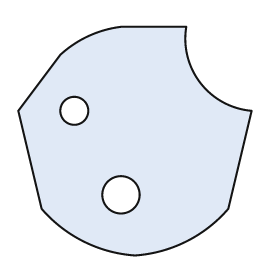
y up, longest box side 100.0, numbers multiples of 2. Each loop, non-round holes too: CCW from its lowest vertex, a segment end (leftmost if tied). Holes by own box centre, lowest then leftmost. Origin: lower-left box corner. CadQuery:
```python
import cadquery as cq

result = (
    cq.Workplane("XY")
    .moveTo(50.0, 0.0)
    .threePointArc((72.0, 6.0), (90.0, 20.0))
    .lineTo(100.0, 62.0)
    .threePointArc((78.0, 74.0), (72.0, 98.0))
    .lineTo(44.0, 98.0)
    .threePointArc((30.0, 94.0), (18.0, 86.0))
    .lineTo(0.0, 62.0)
    .lineTo(10.0, 20.0)
    .threePointArc((28.0, 6.0), (50.0, 0.0))
    .close()
    .moveTo(44.0, 26.0)
    .circle(8.0)
    .moveTo(24.0, 62.0)
    .circle(6.0)
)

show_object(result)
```